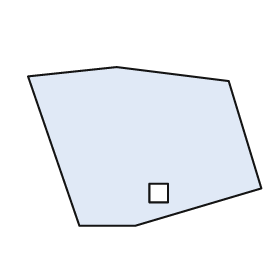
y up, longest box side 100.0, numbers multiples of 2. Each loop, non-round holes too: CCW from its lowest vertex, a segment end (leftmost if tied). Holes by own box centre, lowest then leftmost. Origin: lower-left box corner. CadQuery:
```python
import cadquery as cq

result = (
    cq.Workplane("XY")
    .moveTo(22.0, 0.0)
    .lineTo(46.0, 0.0)
    .lineTo(100.0, 16.0)
    .lineTo(86.0, 62.0)
    .lineTo(38.0, 68.0)
    .lineTo(0.0, 64.0)
    .close()
    .moveTo(52.0, 10.0)
    .lineTo(60.0, 10.0)
    .lineTo(60.0, 18.0)
    .lineTo(52.0, 18.0)
    .close()
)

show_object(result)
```